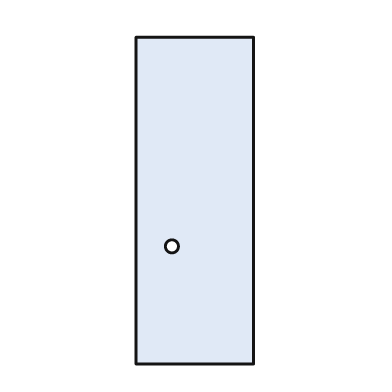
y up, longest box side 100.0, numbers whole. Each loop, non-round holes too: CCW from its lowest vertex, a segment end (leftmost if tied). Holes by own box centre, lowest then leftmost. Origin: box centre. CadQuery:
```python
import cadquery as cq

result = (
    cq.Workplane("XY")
    .moveTo(-18.0, -50.0)
    .lineTo(18.0, -50.0)
    .lineTo(18.0, 50.0)
    .lineTo(-18.0, 50.0)
    .close()
    .moveTo(-7.0, -14.0)
    .circle(2.0)
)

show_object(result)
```